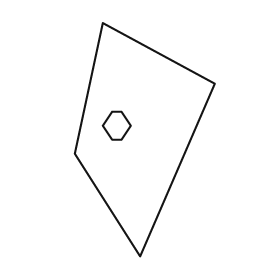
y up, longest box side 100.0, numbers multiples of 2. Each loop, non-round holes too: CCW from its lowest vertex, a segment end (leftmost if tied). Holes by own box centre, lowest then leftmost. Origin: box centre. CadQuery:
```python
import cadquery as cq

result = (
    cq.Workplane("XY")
    .moveTo(-2.0, -50.0)
    .lineTo(30.0, 24.0)
    .lineTo(-18.0, 50.0)
    .lineTo(-30.0, -6.0)
    .close()
    .moveTo(-14.0, 0.0)
    .lineTo(-10.0, 0.0)
    .lineTo(-6.0, 6.0)
    .lineTo(-10.0, 12.0)
    .lineTo(-14.0, 12.0)
    .lineTo(-18.0, 6.0)
    .close()
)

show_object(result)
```